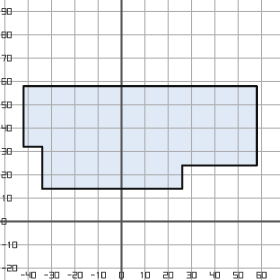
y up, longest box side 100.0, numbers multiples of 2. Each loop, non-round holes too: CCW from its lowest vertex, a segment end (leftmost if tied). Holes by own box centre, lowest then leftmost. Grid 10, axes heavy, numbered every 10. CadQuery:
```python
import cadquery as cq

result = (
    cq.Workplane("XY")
    .moveTo(-34.0, 14.0)
    .lineTo(26.0, 14.0)
    .lineTo(26.0, 24.0)
    .lineTo(58.0, 24.0)
    .lineTo(58.0, 58.0)
    .lineTo(-42.0, 58.0)
    .lineTo(-42.0, 32.0)
    .lineTo(-34.0, 32.0)
    .close()
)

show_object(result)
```